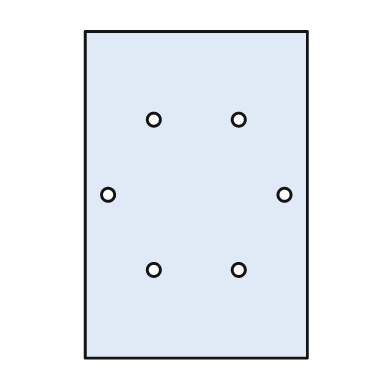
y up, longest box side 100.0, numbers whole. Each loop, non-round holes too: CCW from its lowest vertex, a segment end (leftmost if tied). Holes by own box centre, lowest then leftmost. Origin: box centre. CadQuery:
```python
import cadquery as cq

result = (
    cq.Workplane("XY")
    .moveTo(-34.0, -50.0)
    .lineTo(34.0, -50.0)
    .lineTo(34.0, 50.0)
    .lineTo(-34.0, 50.0)
    .close()
    .moveTo(-13.0, -23.0)
    .circle(2.0)
    .moveTo(13.0, -23.0)
    .circle(2.0)
    .moveTo(-27.0, 0.0)
    .circle(2.0)
    .moveTo(27.0, 0.0)
    .circle(2.0)
    .moveTo(-13.0, 23.0)
    .circle(2.0)
    .moveTo(13.0, 23.0)
    .circle(2.0)
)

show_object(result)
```